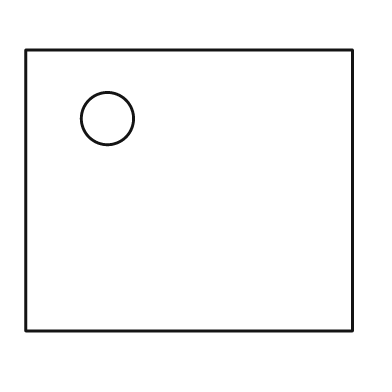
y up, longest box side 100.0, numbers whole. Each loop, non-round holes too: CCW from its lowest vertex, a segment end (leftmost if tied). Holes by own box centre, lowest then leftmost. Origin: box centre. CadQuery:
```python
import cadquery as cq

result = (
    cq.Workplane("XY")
    .moveTo(-50.0, -43.0)
    .lineTo(50.0, -43.0)
    .lineTo(50.0, 43.0)
    .lineTo(-50.0, 43.0)
    .close()
    .moveTo(-25.0, 22.0)
    .circle(8.0)
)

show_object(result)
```